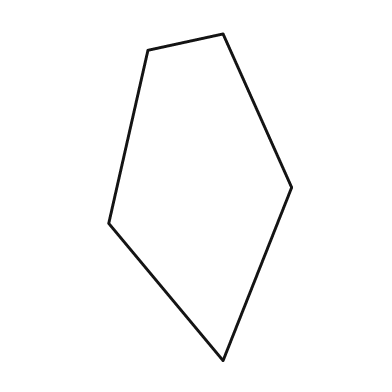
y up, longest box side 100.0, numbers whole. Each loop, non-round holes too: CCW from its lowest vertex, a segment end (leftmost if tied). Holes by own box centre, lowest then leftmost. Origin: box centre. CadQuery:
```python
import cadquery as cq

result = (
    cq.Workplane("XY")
    .moveTo(7.0, -50.0)
    .lineTo(28.0, 3.0)
    .lineTo(7.0, 50.0)
    .lineTo(-16.0, 45.0)
    .lineTo(-28.0, -8.0)
    .close()
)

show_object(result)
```